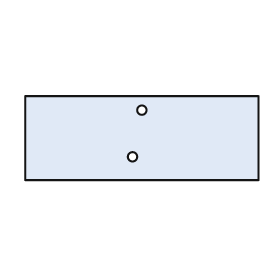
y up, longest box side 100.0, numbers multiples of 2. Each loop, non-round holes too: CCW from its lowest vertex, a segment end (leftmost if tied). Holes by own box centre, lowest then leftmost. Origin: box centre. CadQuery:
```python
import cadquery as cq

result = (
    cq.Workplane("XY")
    .moveTo(-50.0, -18.0)
    .lineTo(50.0, -18.0)
    .lineTo(50.0, 18.0)
    .lineTo(-50.0, 18.0)
    .close()
    .moveTo(-4.0, -8.0)
    .circle(2.0)
    .moveTo(0.0, 12.0)
    .circle(2.0)
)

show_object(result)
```